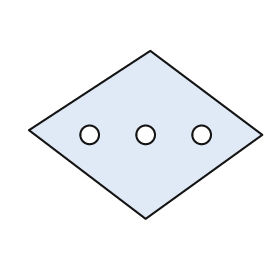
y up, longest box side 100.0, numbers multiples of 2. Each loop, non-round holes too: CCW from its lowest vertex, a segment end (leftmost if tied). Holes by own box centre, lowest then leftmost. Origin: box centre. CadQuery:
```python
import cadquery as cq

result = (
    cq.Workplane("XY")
    .moveTo(0.0, -36.0)
    .lineTo(50.0, 0.0)
    .lineTo(2.0, 36.0)
    .lineTo(-50.0, 2.0)
    .close()
    .moveTo(-24.0, 0.0)
    .circle(4.0)
    .moveTo(0.0, 0.0)
    .circle(4.0)
    .moveTo(24.0, 0.0)
    .circle(4.0)
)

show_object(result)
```